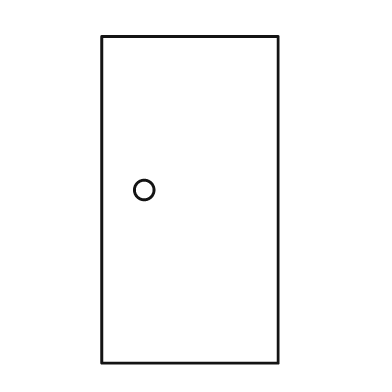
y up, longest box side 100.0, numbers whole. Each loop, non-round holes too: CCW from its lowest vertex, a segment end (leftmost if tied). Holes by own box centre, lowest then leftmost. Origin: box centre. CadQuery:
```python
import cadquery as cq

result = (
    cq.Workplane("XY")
    .moveTo(-27.0, -50.0)
    .lineTo(27.0, -50.0)
    .lineTo(27.0, 50.0)
    .lineTo(-27.0, 50.0)
    .close()
    .moveTo(-14.0, 3.0)
    .circle(3.0)
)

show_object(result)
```